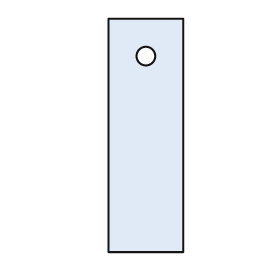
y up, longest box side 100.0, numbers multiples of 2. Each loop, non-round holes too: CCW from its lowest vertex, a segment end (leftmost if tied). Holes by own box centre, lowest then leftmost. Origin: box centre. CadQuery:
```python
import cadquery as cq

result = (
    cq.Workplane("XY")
    .moveTo(-16.0, -50.0)
    .lineTo(16.0, -50.0)
    .lineTo(16.0, 50.0)
    .lineTo(-16.0, 50.0)
    .close()
    .moveTo(0.0, 34.0)
    .circle(4.0)
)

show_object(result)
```